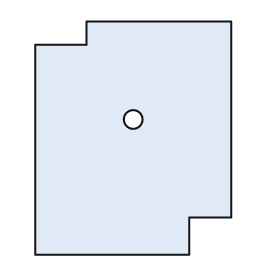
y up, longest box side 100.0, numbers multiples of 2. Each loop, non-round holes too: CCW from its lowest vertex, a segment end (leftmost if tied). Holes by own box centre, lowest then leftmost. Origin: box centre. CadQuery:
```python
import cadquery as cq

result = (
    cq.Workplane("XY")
    .moveTo(-42.0, -50.0)
    .lineTo(24.0, -50.0)
    .lineTo(24.0, -34.0)
    .lineTo(42.0, -34.0)
    .lineTo(42.0, 50.0)
    .lineTo(-20.0, 50.0)
    .lineTo(-20.0, 40.0)
    .lineTo(-42.0, 40.0)
    .close()
    .moveTo(0.0, 8.0)
    .circle(4.0)
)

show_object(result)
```